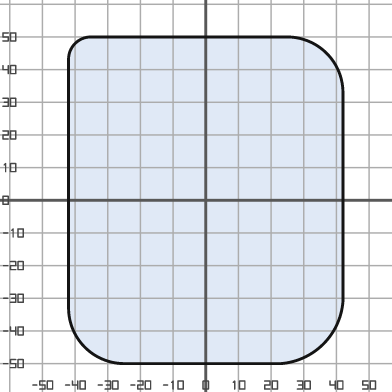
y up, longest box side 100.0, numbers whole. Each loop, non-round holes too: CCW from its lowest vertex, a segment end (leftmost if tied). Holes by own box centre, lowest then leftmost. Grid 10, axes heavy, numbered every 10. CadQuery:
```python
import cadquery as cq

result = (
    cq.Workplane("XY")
    .moveTo(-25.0, -50.0)
    .lineTo(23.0, -50.0)
    .threePointArc((36.0, -44.0), (42.0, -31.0))
    .lineTo(42.0, 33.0)
    .threePointArc((37.0, 45.0), (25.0, 50.0))
    .lineTo(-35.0, 50.0)
    .threePointArc((-40.0, 48.0), (-42.0, 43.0))
    .lineTo(-42.0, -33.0)
    .threePointArc((-37.0, -45.0), (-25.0, -50.0))
    .close()
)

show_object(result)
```